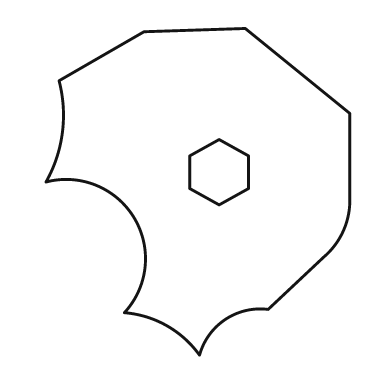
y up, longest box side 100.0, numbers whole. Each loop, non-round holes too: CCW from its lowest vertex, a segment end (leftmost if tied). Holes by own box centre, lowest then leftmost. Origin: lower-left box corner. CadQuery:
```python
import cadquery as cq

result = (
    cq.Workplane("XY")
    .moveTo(47.0, 0.0)
    .threePointArc((55.0, 11.0), (68.0, 14.0))
    .lineTo(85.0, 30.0)
    .threePointArc((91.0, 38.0), (93.0, 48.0))
    .lineTo(93.0, 74.0)
    .lineTo(61.0, 100.0)
    .lineTo(30.0, 99.0)
    .lineTo(4.0, 84.0)
    .threePointArc((5.0, 68.0), (0.0, 53.0))
    .threePointArc((27.0, 42.0), (24.0, 13.0))
    .threePointArc((37.0, 9.0), (47.0, 0.0))
    .close()
    .moveTo(53.0, 46.0)
    .lineTo(62.0, 51.0)
    .lineTo(62.0, 61.0)
    .lineTo(53.0, 66.0)
    .lineTo(44.0, 61.0)
    .lineTo(44.0, 51.0)
    .close()
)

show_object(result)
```